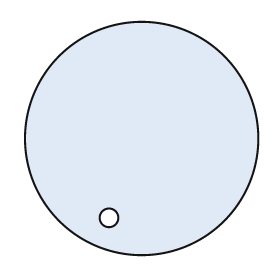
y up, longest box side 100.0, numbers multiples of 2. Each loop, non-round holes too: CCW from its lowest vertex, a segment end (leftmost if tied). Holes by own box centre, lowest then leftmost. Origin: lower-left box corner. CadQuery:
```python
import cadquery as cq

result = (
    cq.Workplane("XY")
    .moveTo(50.0, 50.0)
    .circle(50.0)
    .moveTo(36.0, 16.0)
    .circle(4.0)
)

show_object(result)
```